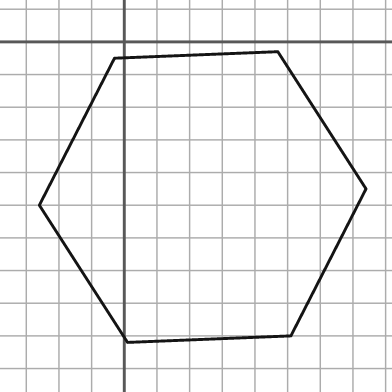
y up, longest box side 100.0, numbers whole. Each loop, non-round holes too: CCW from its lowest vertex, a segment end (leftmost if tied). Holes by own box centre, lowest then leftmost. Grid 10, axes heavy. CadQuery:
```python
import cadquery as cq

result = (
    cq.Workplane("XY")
    .moveTo(1.0, -92.0)
    .lineTo(51.0, -90.0)
    .lineTo(74.0, -45.0)
    .lineTo(47.0, -3.0)
    .lineTo(-3.0, -5.0)
    .lineTo(-26.0, -50.0)
    .close()
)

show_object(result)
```